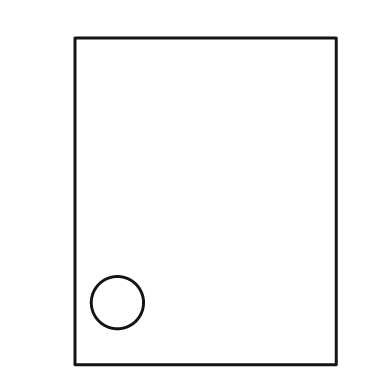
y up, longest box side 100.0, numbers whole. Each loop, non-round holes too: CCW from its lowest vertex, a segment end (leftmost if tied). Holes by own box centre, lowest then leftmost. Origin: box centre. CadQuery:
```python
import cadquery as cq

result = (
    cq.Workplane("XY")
    .moveTo(-40.0, -50.0)
    .lineTo(40.0, -50.0)
    .lineTo(40.0, 50.0)
    .lineTo(-40.0, 50.0)
    .close()
    .moveTo(-27.0, -31.0)
    .circle(8.0)
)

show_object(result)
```